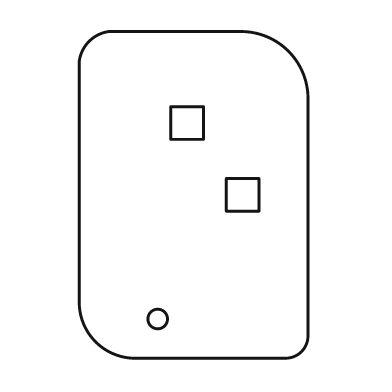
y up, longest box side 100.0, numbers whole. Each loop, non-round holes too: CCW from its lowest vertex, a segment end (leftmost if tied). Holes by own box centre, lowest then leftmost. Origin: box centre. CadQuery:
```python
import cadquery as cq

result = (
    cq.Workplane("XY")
    .moveTo(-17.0, -50.0)
    .lineTo(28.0, -50.0)
    .threePointArc((33.0, -48.0), (35.0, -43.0))
    .lineTo(35.0, 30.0)
    .threePointArc((29.0, 44.0), (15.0, 50.0))
    .lineTo(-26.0, 50.0)
    .threePointArc((-32.0, 47.0), (-35.0, 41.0))
    .lineTo(-35.0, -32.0)
    .threePointArc((-30.0, -45.0), (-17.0, -50.0))
    .close()
    .moveTo(-11.0, -38.0)
    .circle(3.0)
    .moveTo(10.0, -5.0)
    .lineTo(20.0, -5.0)
    .lineTo(20.0, 5.0)
    .lineTo(10.0, 5.0)
    .close()
    .moveTo(-7.0, 17.0)
    .lineTo(3.0, 17.0)
    .lineTo(3.0, 27.0)
    .lineTo(-7.0, 27.0)
    .close()
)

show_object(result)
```